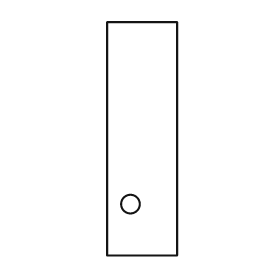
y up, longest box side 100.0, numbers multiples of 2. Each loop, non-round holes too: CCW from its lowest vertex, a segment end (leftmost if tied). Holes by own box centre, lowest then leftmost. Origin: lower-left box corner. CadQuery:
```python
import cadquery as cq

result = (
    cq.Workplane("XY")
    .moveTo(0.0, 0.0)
    .lineTo(30.0, 0.0)
    .lineTo(30.0, 100.0)
    .lineTo(0.0, 100.0)
    .close()
    .moveTo(10.0, 22.0)
    .circle(4.0)
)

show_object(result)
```